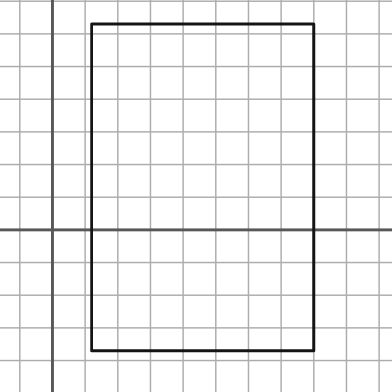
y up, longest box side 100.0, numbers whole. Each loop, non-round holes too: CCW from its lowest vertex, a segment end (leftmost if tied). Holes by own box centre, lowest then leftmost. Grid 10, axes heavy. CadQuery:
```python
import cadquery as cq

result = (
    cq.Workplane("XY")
    .moveTo(12.0, -37.0)
    .lineTo(80.0, -37.0)
    .lineTo(80.0, 63.0)
    .lineTo(12.0, 63.0)
    .close()
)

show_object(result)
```